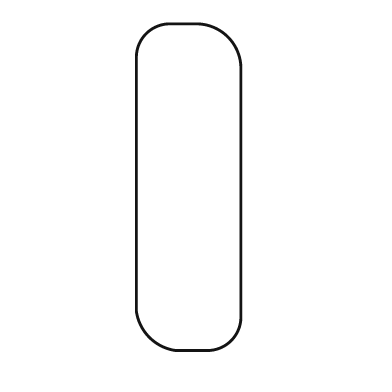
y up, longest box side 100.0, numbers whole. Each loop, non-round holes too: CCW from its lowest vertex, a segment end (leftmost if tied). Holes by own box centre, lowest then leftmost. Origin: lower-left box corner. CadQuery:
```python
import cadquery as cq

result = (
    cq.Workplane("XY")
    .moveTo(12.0, 0.0)
    .lineTo(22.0, 0.0)
    .threePointArc((29.0, 3.0), (32.0, 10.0))
    .lineTo(32.0, 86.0)
    .threePointArc((28.0, 96.0), (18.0, 100.0))
    .lineTo(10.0, 100.0)
    .threePointArc((3.0, 97.0), (0.0, 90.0))
    .lineTo(0.0, 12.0)
    .threePointArc((4.0, 4.0), (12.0, 0.0))
    .close()
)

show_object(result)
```